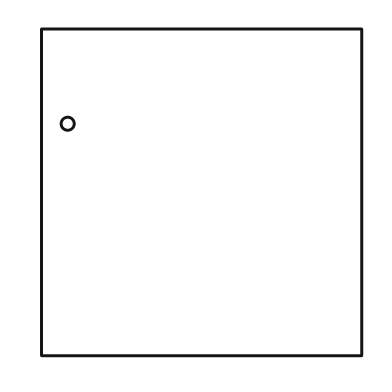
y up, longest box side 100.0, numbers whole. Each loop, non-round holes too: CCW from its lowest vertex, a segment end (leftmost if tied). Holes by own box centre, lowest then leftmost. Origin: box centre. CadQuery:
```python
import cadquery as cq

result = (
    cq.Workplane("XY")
    .moveTo(-49.0, -50.0)
    .lineTo(49.0, -50.0)
    .lineTo(49.0, 50.0)
    .lineTo(-49.0, 50.0)
    .close()
    .moveTo(-41.0, 21.0)
    .circle(2.0)
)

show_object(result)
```